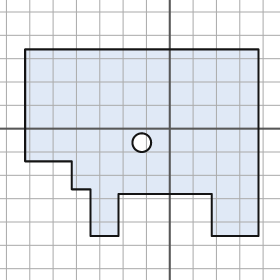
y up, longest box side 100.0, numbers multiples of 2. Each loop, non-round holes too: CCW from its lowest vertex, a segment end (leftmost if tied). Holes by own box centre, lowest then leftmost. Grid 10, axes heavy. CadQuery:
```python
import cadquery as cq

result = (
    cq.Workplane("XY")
    .moveTo(-34.0, -46.0)
    .lineTo(-22.0, -46.0)
    .lineTo(-22.0, -28.0)
    .lineTo(18.0, -28.0)
    .lineTo(18.0, -46.0)
    .lineTo(38.0, -46.0)
    .lineTo(38.0, 34.0)
    .lineTo(-62.0, 34.0)
    .lineTo(-62.0, -14.0)
    .lineTo(-42.0, -14.0)
    .lineTo(-42.0, -26.0)
    .lineTo(-34.0, -26.0)
    .close()
    .moveTo(-12.0, -6.0)
    .circle(4.0)
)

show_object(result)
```